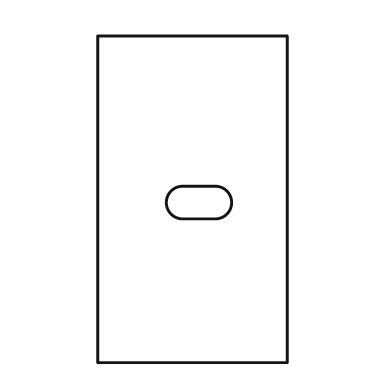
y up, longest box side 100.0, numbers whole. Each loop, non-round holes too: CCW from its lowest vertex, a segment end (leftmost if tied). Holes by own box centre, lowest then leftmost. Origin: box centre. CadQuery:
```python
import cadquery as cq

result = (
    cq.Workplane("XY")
    .moveTo(-29.0, -50.0)
    .lineTo(29.0, -50.0)
    .lineTo(29.0, 50.0)
    .lineTo(-29.0, 50.0)
    .close()
    .moveTo(-3.0, -6.0)
    .lineTo(7.0, -6.0)
    .threePointArc((12.0, -1.0), (7.0, 4.0))
    .lineTo(-3.0, 4.0)
    .threePointArc((-8.0, -1.0), (-3.0, -6.0))
    .close()
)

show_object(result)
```